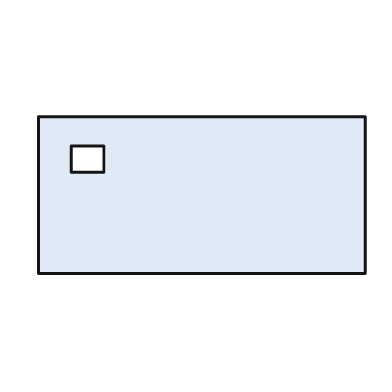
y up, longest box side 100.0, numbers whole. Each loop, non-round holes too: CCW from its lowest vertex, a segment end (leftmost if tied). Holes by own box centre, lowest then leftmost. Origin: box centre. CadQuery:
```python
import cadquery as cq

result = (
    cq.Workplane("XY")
    .moveTo(-50.0, -24.0)
    .lineTo(50.0, -24.0)
    .lineTo(50.0, 24.0)
    .lineTo(-50.0, 24.0)
    .close()
    .moveTo(-40.0, 7.0)
    .lineTo(-30.0, 7.0)
    .lineTo(-30.0, 15.0)
    .lineTo(-40.0, 15.0)
    .close()
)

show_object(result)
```